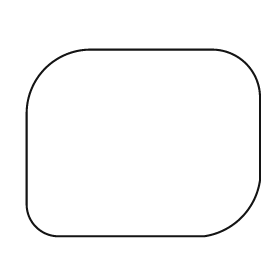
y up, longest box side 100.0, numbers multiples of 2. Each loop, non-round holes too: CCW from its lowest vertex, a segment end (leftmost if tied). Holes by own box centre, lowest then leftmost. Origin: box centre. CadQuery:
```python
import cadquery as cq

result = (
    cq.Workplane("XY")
    .moveTo(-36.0, -40.0)
    .lineTo(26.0, -40.0)
    .threePointArc((42.0, -32.0), (50.0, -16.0))
    .lineTo(50.0, 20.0)
    .threePointArc((44.0, 34.0), (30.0, 40.0))
    .lineTo(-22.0, 40.0)
    .threePointArc((-42.0, 32.0), (-50.0, 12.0))
    .lineTo(-50.0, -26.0)
    .threePointArc((-46.0, -36.0), (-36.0, -40.0))
    .close()
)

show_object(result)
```